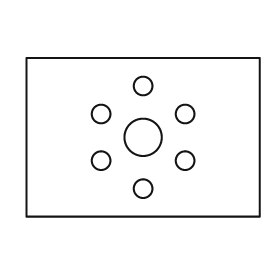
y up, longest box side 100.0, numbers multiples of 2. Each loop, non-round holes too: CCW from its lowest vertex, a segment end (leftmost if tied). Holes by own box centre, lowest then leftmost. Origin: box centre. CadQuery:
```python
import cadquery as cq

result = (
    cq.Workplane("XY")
    .moveTo(-50.0, -34.0)
    .lineTo(50.0, -34.0)
    .lineTo(50.0, 34.0)
    .lineTo(-50.0, 34.0)
    .close()
    .moveTo(0.0, -22.0)
    .circle(4.0)
    .moveTo(-18.0, -10.0)
    .circle(4.0)
    .moveTo(18.0, -10.0)
    .circle(4.0)
    .moveTo(0.0, 0.0)
    .circle(8.0)
    .moveTo(-18.0, 10.0)
    .circle(4.0)
    .moveTo(18.0, 10.0)
    .circle(4.0)
    .moveTo(0.0, 22.0)
    .circle(4.0)
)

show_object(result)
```